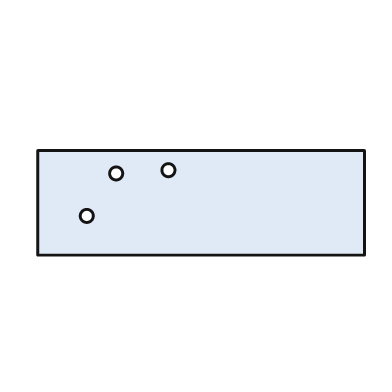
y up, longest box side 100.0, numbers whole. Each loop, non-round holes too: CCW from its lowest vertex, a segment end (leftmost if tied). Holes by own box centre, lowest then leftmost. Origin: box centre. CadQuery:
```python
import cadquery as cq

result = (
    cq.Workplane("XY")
    .moveTo(-50.0, -16.0)
    .lineTo(50.0, -16.0)
    .lineTo(50.0, 16.0)
    .lineTo(-50.0, 16.0)
    .close()
    .moveTo(-35.0, -4.0)
    .circle(2.0)
    .moveTo(-26.0, 9.0)
    .circle(2.0)
    .moveTo(-10.0, 10.0)
    .circle(2.0)
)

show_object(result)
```